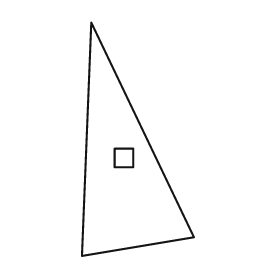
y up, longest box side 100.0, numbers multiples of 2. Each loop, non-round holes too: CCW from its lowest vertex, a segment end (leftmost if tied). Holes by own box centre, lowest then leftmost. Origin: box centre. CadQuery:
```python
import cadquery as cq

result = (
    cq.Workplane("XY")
    .moveTo(-24.0, -50.0)
    .lineTo(24.0, -42.0)
    .lineTo(-20.0, 50.0)
    .close()
    .moveTo(-10.0, -12.0)
    .lineTo(-2.0, -12.0)
    .lineTo(-2.0, -4.0)
    .lineTo(-10.0, -4.0)
    .close()
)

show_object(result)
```